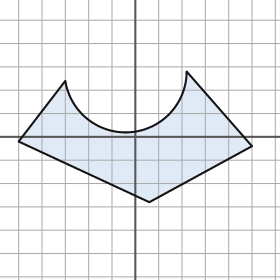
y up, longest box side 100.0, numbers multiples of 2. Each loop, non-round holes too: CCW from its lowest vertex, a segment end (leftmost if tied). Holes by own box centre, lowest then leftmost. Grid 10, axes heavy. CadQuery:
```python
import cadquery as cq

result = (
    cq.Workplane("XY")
    .moveTo(6.0, -28.0)
    .lineTo(50.0, -4.0)
    .lineTo(22.0, 28.0)
    .threePointArc((-2.0, 2.0), (-30.0, 24.0))
    .lineTo(-50.0, -2.0)
    .close()
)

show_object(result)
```